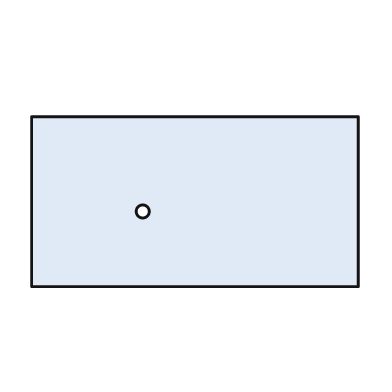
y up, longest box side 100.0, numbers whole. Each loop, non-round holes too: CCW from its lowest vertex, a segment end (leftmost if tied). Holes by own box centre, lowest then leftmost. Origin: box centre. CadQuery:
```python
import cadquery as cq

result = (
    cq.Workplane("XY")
    .moveTo(-50.0, -26.0)
    .lineTo(50.0, -26.0)
    .lineTo(50.0, 26.0)
    .lineTo(-50.0, 26.0)
    .close()
    .moveTo(-16.0, -3.0)
    .circle(2.0)
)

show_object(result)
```